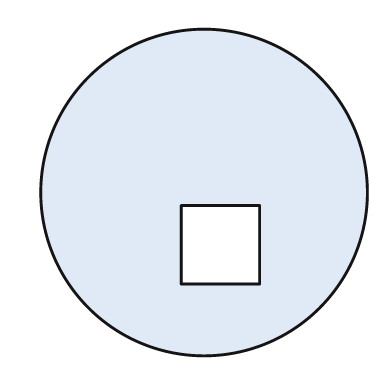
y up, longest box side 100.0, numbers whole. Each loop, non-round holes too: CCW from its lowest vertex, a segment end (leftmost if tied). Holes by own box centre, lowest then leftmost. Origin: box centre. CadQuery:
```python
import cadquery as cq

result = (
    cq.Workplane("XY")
    .moveTo(0.0, 0.0)
    .circle(50.0)
    .moveTo(-7.0, -28.0)
    .lineTo(17.0, -28.0)
    .lineTo(17.0, -4.0)
    .lineTo(-7.0, -4.0)
    .close()
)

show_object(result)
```